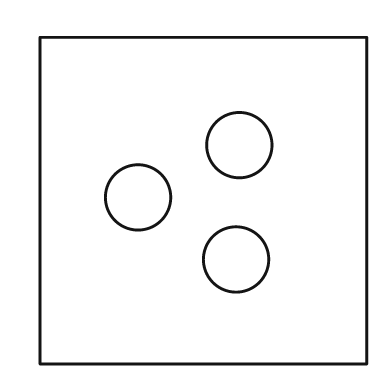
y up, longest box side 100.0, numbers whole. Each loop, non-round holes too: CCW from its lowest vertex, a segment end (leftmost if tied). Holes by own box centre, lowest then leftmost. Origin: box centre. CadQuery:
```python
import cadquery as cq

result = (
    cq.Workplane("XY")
    .moveTo(-50.0, -50.0)
    .lineTo(50.0, -50.0)
    .lineTo(50.0, 50.0)
    .lineTo(-50.0, 50.0)
    .close()
    .moveTo(10.0, -18.0)
    .circle(10.0)
    .moveTo(-20.0, 1.0)
    .circle(10.0)
    .moveTo(11.0, 17.0)
    .circle(10.0)
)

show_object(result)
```